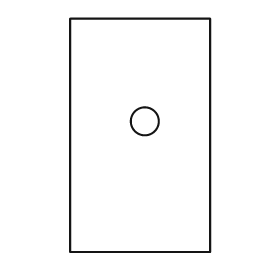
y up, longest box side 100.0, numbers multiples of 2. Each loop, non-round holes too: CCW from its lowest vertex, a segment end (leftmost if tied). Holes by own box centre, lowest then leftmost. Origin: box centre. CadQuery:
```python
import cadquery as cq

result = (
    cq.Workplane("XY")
    .moveTo(-30.0, -50.0)
    .lineTo(30.0, -50.0)
    .lineTo(30.0, 50.0)
    .lineTo(-30.0, 50.0)
    .close()
    .moveTo(2.0, 6.0)
    .circle(6.0)
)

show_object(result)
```